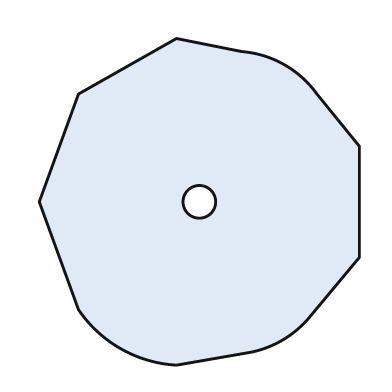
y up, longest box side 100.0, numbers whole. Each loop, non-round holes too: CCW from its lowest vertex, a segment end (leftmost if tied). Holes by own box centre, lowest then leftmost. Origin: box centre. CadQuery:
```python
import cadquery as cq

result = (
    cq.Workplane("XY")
    .moveTo(-7.0, -50.0)
    .lineTo(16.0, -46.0)
    .threePointArc((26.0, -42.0), (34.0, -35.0))
    .lineTo(49.0, -17.0)
    .lineTo(49.0, 17.0)
    .lineTo(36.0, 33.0)
    .threePointArc((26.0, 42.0), (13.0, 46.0))
    .lineTo(-7.0, 50.0)
    .lineTo(-37.0, 33.0)
    .lineTo(-49.0, 0.0)
    .lineTo(-37.0, -33.0)
    .threePointArc((-24.0, -45.0), (-7.0, -50.0))
    .close()
    .moveTo(0.0, 0.0)
    .circle(5.0)
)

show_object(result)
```